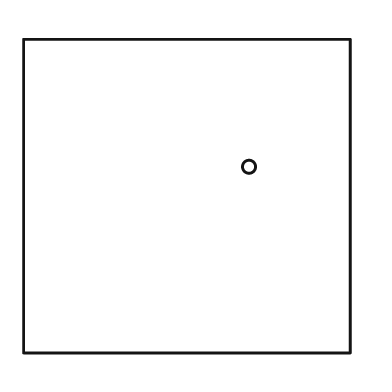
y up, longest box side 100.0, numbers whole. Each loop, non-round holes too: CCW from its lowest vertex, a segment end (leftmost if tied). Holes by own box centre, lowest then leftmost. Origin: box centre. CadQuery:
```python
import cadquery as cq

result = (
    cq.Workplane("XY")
    .moveTo(-50.0, -48.0)
    .lineTo(50.0, -48.0)
    .lineTo(50.0, 48.0)
    .lineTo(-50.0, 48.0)
    .close()
    .moveTo(19.0, 9.0)
    .circle(2.0)
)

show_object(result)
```